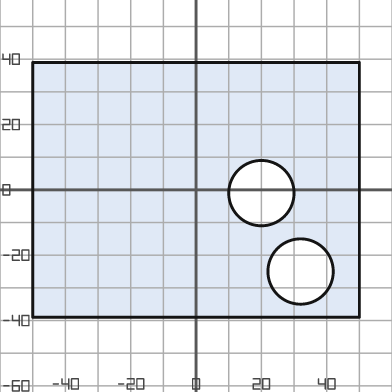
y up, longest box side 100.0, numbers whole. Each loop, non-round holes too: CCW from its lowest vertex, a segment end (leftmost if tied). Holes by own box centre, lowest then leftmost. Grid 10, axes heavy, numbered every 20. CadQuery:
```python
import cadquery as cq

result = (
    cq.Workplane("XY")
    .moveTo(-50.0, -39.0)
    .lineTo(50.0, -39.0)
    .lineTo(50.0, 39.0)
    .lineTo(-50.0, 39.0)
    .close()
    .moveTo(32.0, -25.0)
    .circle(10.0)
    .moveTo(20.0, -1.0)
    .circle(10.0)
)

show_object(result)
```